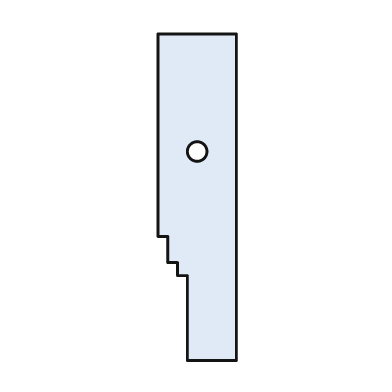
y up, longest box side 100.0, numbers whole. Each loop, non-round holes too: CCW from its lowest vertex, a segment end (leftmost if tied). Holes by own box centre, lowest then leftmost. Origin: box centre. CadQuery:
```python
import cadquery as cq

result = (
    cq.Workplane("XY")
    .moveTo(-3.0, -50.0)
    .lineTo(12.0, -50.0)
    .lineTo(12.0, 50.0)
    .lineTo(-12.0, 50.0)
    .lineTo(-12.0, -12.0)
    .lineTo(-9.0, -12.0)
    .lineTo(-9.0, -20.0)
    .lineTo(-6.0, -20.0)
    .lineTo(-6.0, -24.0)
    .lineTo(-3.0, -24.0)
    .close()
    .moveTo(0.0, 14.0)
    .circle(3.0)
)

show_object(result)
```